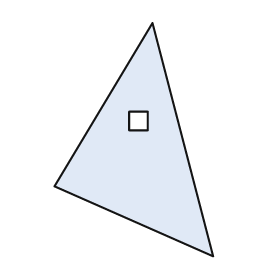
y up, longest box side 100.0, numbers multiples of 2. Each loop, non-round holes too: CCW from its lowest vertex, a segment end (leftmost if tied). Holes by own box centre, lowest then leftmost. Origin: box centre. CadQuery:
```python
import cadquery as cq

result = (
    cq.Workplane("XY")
    .moveTo(34.0, -50.0)
    .lineTo(8.0, 50.0)
    .lineTo(-34.0, -20.0)
    .close()
    .moveTo(-2.0, 4.0)
    .lineTo(6.0, 4.0)
    .lineTo(6.0, 12.0)
    .lineTo(-2.0, 12.0)
    .close()
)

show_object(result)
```